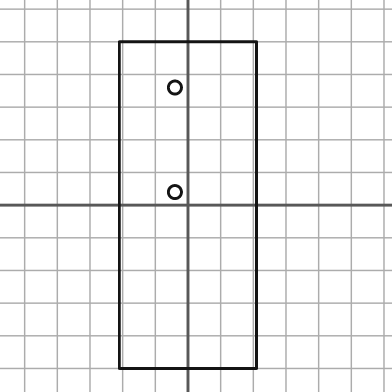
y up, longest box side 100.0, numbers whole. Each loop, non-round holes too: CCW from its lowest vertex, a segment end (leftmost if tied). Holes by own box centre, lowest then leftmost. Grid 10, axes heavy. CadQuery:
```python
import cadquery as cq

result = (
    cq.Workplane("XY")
    .moveTo(-21.0, -50.0)
    .lineTo(21.0, -50.0)
    .lineTo(21.0, 50.0)
    .lineTo(-21.0, 50.0)
    .close()
    .moveTo(-4.0, 4.0)
    .circle(2.0)
    .moveTo(-4.0, 36.0)
    .circle(2.0)
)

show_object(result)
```